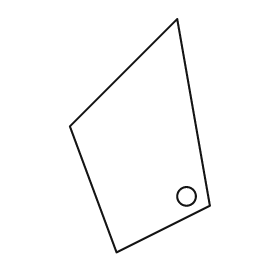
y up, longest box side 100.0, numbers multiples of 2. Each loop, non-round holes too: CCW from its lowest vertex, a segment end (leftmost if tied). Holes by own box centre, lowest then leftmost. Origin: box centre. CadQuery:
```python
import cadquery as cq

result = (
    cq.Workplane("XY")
    .moveTo(-10.0, -50.0)
    .lineTo(30.0, -30.0)
    .lineTo(16.0, 50.0)
    .lineTo(-30.0, 4.0)
    .close()
    .moveTo(20.0, -26.0)
    .circle(4.0)
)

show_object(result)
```